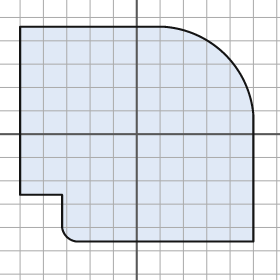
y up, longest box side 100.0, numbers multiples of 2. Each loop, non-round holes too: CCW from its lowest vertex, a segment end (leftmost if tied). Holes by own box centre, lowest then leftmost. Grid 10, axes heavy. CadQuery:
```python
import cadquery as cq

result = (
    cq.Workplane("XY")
    .moveTo(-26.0, -46.0)
    .lineTo(50.0, -46.0)
    .lineTo(50.0, 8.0)
    .threePointArc((38.0, 34.0), (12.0, 46.0))
    .lineTo(-50.0, 46.0)
    .lineTo(-50.0, -26.0)
    .lineTo(-32.0, -26.0)
    .lineTo(-32.0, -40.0)
    .threePointArc((-30.0, -44.0), (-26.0, -46.0))
    .close()
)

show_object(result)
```